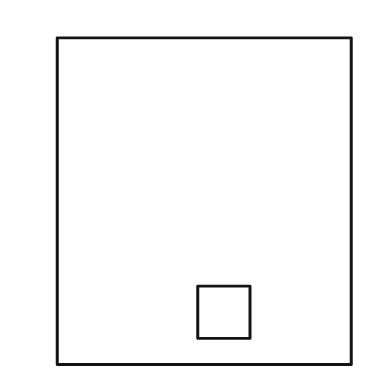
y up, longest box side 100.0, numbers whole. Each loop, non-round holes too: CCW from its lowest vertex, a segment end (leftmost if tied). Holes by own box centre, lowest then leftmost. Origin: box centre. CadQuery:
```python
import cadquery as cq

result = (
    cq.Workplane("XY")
    .moveTo(-45.0, -50.0)
    .lineTo(45.0, -50.0)
    .lineTo(45.0, 50.0)
    .lineTo(-45.0, 50.0)
    .close()
    .moveTo(-2.0, -42.0)
    .lineTo(14.0, -42.0)
    .lineTo(14.0, -26.0)
    .lineTo(-2.0, -26.0)
    .close()
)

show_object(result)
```